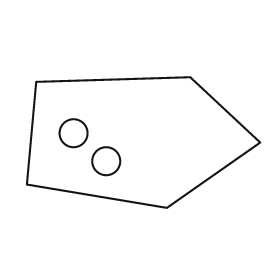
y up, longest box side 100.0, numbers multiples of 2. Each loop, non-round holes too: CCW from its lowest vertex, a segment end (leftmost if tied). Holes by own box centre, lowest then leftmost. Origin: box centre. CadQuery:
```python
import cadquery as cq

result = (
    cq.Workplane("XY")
    .moveTo(10.0, -28.0)
    .lineTo(50.0, 0.0)
    .lineTo(20.0, 28.0)
    .lineTo(-46.0, 26.0)
    .lineTo(-50.0, -18.0)
    .close()
    .moveTo(-16.0, -8.0)
    .circle(6.0)
    .moveTo(-30.0, 4.0)
    .circle(6.0)
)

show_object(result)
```